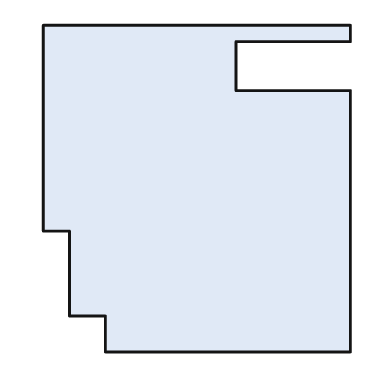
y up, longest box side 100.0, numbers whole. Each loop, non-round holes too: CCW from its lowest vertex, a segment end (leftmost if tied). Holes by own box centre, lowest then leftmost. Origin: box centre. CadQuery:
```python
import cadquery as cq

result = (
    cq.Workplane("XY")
    .moveTo(-28.0, -50.0)
    .lineTo(47.0, -50.0)
    .lineTo(47.0, 30.0)
    .lineTo(12.0, 30.0)
    .lineTo(12.0, 45.0)
    .lineTo(47.0, 45.0)
    .lineTo(47.0, 50.0)
    .lineTo(-47.0, 50.0)
    .lineTo(-47.0, -13.0)
    .lineTo(-39.0, -13.0)
    .lineTo(-39.0, -39.0)
    .lineTo(-28.0, -39.0)
    .close()
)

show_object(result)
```